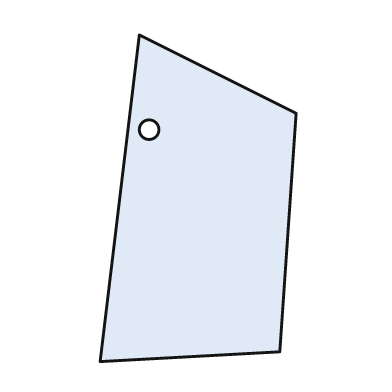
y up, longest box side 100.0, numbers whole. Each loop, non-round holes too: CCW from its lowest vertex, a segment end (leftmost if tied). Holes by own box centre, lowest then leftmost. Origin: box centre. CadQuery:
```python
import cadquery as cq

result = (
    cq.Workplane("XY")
    .moveTo(-30.0, -50.0)
    .lineTo(25.0, -47.0)
    .lineTo(30.0, 26.0)
    .lineTo(-18.0, 50.0)
    .close()
    .moveTo(-15.0, 21.0)
    .circle(3.0)
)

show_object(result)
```